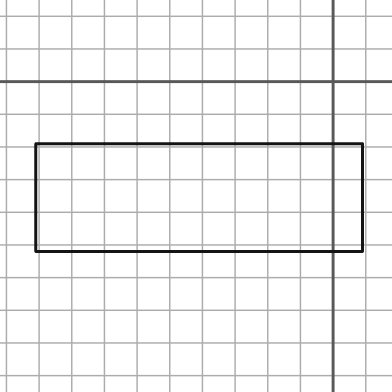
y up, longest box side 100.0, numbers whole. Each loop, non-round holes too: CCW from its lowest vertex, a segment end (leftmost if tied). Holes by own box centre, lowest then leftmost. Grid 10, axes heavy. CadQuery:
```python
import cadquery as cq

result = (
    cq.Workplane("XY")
    .moveTo(-91.0, -52.0)
    .lineTo(9.0, -52.0)
    .lineTo(9.0, -19.0)
    .lineTo(-91.0, -19.0)
    .close()
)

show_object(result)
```